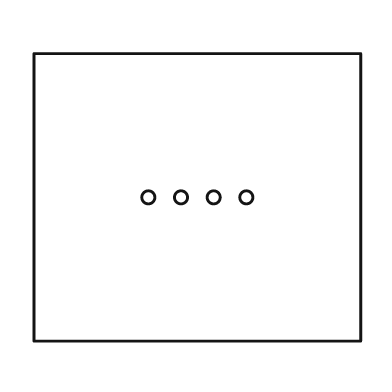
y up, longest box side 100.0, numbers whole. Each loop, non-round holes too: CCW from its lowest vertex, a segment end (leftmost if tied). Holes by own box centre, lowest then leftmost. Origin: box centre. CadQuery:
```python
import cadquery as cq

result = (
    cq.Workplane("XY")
    .moveTo(-50.0, -44.0)
    .lineTo(50.0, -44.0)
    .lineTo(50.0, 44.0)
    .lineTo(-50.0, 44.0)
    .close()
    .moveTo(-15.0, 0.0)
    .circle(2.0)
    .moveTo(-5.0, 0.0)
    .circle(2.0)
    .moveTo(5.0, 0.0)
    .circle(2.0)
    .moveTo(15.0, 0.0)
    .circle(2.0)
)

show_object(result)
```